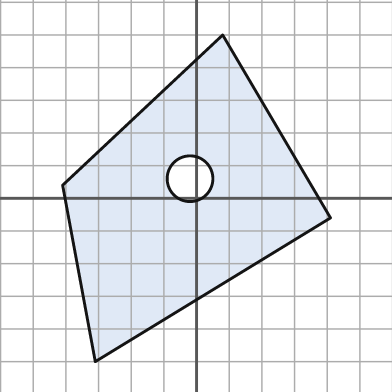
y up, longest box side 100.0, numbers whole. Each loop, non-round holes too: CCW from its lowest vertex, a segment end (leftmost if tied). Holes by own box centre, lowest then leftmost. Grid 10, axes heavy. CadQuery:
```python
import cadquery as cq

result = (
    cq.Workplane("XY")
    .moveTo(-31.0, -50.0)
    .lineTo(41.0, -6.0)
    .lineTo(8.0, 50.0)
    .lineTo(-41.0, 4.0)
    .close()
    .moveTo(-2.0, 6.0)
    .circle(7.0)
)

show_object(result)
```